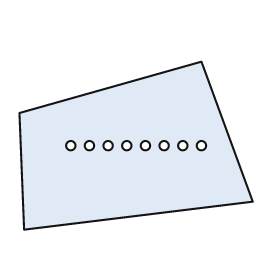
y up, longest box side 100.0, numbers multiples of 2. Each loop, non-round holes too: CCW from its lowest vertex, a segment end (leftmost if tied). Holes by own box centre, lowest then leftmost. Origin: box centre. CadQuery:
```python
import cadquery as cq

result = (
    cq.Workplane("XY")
    .moveTo(-48.0, -36.0)
    .lineTo(50.0, -24.0)
    .lineTo(28.0, 36.0)
    .lineTo(-50.0, 14.0)
    .close()
    .moveTo(-28.0, 0.0)
    .circle(2.0)
    .moveTo(-20.0, 0.0)
    .circle(2.0)
    .moveTo(-12.0, 0.0)
    .circle(2.0)
    .moveTo(-4.0, 0.0)
    .circle(2.0)
    .moveTo(4.0, 0.0)
    .circle(2.0)
    .moveTo(12.0, 0.0)
    .circle(2.0)
    .moveTo(20.0, 0.0)
    .circle(2.0)
    .moveTo(28.0, 0.0)
    .circle(2.0)
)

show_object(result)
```